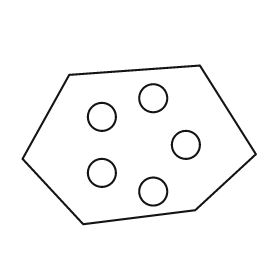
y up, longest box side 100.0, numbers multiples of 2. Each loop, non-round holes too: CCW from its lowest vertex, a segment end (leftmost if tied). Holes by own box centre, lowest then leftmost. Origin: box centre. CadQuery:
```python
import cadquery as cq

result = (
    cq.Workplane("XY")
    .moveTo(-24.0, -34.0)
    .lineTo(24.0, -28.0)
    .lineTo(50.0, -4.0)
    .lineTo(26.0, 34.0)
    .lineTo(-30.0, 30.0)
    .lineTo(-50.0, -6.0)
    .close()
    .moveTo(6.0, -20.0)
    .circle(6.0)
    .moveTo(-16.0, -12.0)
    .circle(6.0)
    .moveTo(20.0, 0.0)
    .circle(6.0)
    .moveTo(-16.0, 12.0)
    .circle(6.0)
    .moveTo(6.0, 20.0)
    .circle(6.0)
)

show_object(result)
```